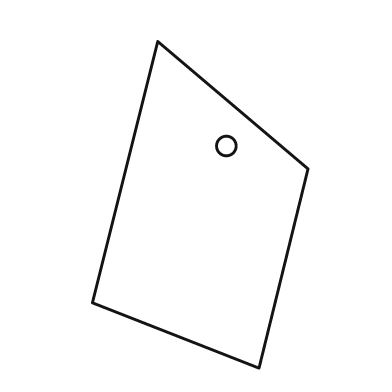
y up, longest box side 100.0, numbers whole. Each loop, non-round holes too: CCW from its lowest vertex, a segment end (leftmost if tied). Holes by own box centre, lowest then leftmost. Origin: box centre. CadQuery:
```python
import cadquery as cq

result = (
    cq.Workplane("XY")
    .moveTo(18.0, -50.0)
    .lineTo(33.0, 11.0)
    .lineTo(-13.0, 50.0)
    .lineTo(-33.0, -30.0)
    .close()
    .moveTo(8.0, 18.0)
    .circle(3.0)
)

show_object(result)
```